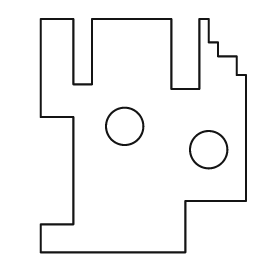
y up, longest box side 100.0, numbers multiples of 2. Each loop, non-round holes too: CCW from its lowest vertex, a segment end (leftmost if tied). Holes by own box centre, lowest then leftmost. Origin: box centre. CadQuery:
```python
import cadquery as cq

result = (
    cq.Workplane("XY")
    .moveTo(-44.0, -50.0)
    .lineTo(18.0, -50.0)
    .lineTo(18.0, -28.0)
    .lineTo(44.0, -28.0)
    .lineTo(44.0, 26.0)
    .lineTo(40.0, 26.0)
    .lineTo(40.0, 34.0)
    .lineTo(32.0, 34.0)
    .lineTo(32.0, 40.0)
    .lineTo(28.0, 40.0)
    .lineTo(28.0, 50.0)
    .lineTo(24.0, 50.0)
    .lineTo(24.0, 20.0)
    .lineTo(12.0, 20.0)
    .lineTo(12.0, 50.0)
    .lineTo(-22.0, 50.0)
    .lineTo(-22.0, 22.0)
    .lineTo(-30.0, 22.0)
    .lineTo(-30.0, 50.0)
    .lineTo(-44.0, 50.0)
    .lineTo(-44.0, 8.0)
    .lineTo(-30.0, 8.0)
    .lineTo(-30.0, -38.0)
    .lineTo(-44.0, -38.0)
    .close()
    .moveTo(28.0, -6.0)
    .circle(8.0)
    .moveTo(-8.0, 4.0)
    .circle(8.0)
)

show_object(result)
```